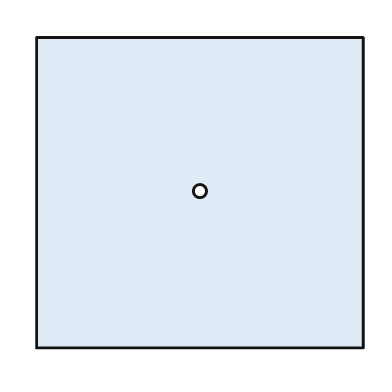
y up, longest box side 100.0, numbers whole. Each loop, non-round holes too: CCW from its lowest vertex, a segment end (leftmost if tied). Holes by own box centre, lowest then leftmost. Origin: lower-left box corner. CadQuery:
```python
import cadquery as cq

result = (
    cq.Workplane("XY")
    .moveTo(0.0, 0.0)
    .lineTo(100.0, 0.0)
    .lineTo(100.0, 95.0)
    .lineTo(0.0, 95.0)
    .close()
    .moveTo(50.0, 48.0)
    .circle(2.0)
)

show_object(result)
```